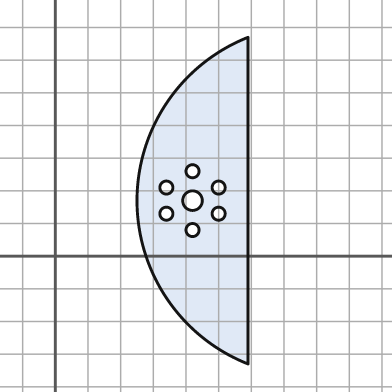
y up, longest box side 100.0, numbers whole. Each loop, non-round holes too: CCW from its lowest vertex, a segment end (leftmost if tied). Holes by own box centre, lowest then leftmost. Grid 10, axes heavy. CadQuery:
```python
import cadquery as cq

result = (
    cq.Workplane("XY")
    .moveTo(59.0, -33.0)
    .lineTo(59.0, 67.0)
    .threePointArc((25.0, 17.0), (59.0, -33.0))
    .close()
    .moveTo(42.0, 8.0)
    .circle(2.0)
    .moveTo(34.0, 13.0)
    .circle(2.0)
    .moveTo(50.0, 13.0)
    .circle(2.0)
    .moveTo(42.0, 17.0)
    .circle(3.0)
    .moveTo(34.0, 21.0)
    .circle(2.0)
    .moveTo(50.0, 21.0)
    .circle(2.0)
    .moveTo(42.0, 26.0)
    .circle(2.0)
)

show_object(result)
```